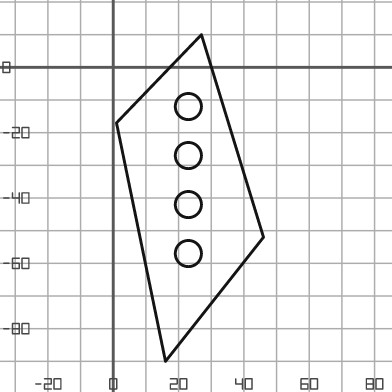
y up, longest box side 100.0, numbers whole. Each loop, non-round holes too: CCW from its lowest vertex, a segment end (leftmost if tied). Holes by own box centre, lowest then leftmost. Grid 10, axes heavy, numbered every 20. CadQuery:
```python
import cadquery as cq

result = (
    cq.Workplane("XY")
    .moveTo(16.0, -90.0)
    .lineTo(46.0, -52.0)
    .lineTo(27.0, 10.0)
    .lineTo(1.0, -17.0)
    .close()
    .moveTo(23.0, -57.0)
    .circle(4.0)
    .moveTo(23.0, -42.0)
    .circle(4.0)
    .moveTo(23.0, -27.0)
    .circle(4.0)
    .moveTo(23.0, -12.0)
    .circle(4.0)
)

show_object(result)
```